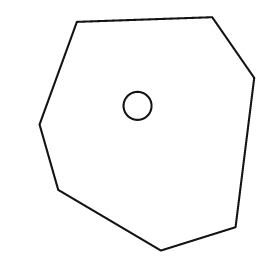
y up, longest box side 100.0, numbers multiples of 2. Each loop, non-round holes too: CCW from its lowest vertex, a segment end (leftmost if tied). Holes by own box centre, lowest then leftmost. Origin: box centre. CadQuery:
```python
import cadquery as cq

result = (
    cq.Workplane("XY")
    .moveTo(6.0, -50.0)
    .lineTo(38.0, -40.0)
    .lineTo(46.0, 24.0)
    .lineTo(28.0, 50.0)
    .lineTo(-30.0, 48.0)
    .lineTo(-46.0, 4.0)
    .lineTo(-38.0, -24.0)
    .close()
    .moveTo(-4.0, 12.0)
    .circle(6.0)
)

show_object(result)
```